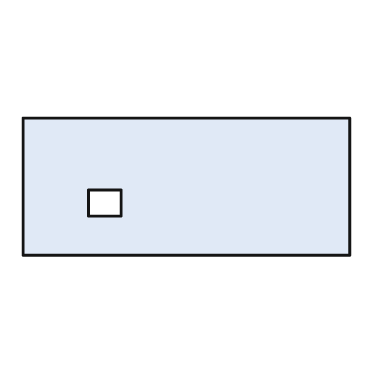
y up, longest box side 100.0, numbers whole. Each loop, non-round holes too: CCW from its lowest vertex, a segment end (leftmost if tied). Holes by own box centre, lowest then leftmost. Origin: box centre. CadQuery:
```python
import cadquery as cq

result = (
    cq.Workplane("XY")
    .moveTo(-50.0, -21.0)
    .lineTo(50.0, -21.0)
    .lineTo(50.0, 21.0)
    .lineTo(-50.0, 21.0)
    .close()
    .moveTo(-30.0, -9.0)
    .lineTo(-20.0, -9.0)
    .lineTo(-20.0, -1.0)
    .lineTo(-30.0, -1.0)
    .close()
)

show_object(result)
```